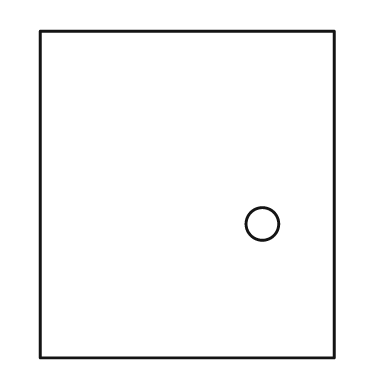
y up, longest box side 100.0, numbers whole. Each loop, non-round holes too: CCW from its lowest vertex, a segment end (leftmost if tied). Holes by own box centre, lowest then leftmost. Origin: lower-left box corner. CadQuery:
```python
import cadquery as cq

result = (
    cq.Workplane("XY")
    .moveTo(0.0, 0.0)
    .lineTo(90.0, 0.0)
    .lineTo(90.0, 100.0)
    .lineTo(0.0, 100.0)
    .close()
    .moveTo(68.0, 41.0)
    .circle(5.0)
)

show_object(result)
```